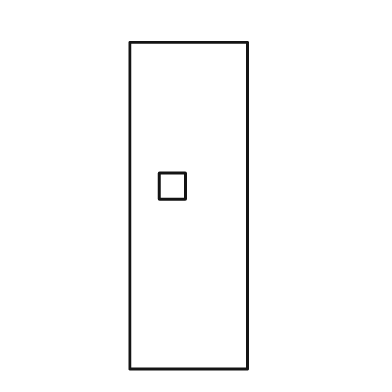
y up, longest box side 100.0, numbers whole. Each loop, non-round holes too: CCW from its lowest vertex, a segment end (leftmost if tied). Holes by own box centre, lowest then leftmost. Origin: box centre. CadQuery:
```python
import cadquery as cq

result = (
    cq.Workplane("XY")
    .moveTo(-18.0, -50.0)
    .lineTo(18.0, -50.0)
    .lineTo(18.0, 50.0)
    .lineTo(-18.0, 50.0)
    .close()
    .moveTo(-9.0, 2.0)
    .lineTo(-1.0, 2.0)
    .lineTo(-1.0, 10.0)
    .lineTo(-9.0, 10.0)
    .close()
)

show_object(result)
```